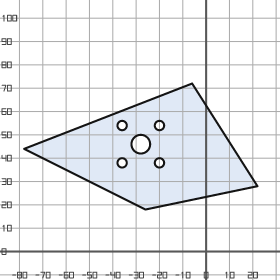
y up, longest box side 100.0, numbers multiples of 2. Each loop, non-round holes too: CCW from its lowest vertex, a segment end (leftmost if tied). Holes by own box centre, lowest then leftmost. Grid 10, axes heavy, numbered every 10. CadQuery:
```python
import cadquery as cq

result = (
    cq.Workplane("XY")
    .moveTo(-26.0, 18.0)
    .lineTo(22.0, 28.0)
    .lineTo(-6.0, 72.0)
    .lineTo(-78.0, 44.0)
    .close()
    .moveTo(-36.0, 38.0)
    .circle(2.0)
    .moveTo(-20.0, 38.0)
    .circle(2.0)
    .moveTo(-28.0, 46.0)
    .circle(4.0)
    .moveTo(-36.0, 54.0)
    .circle(2.0)
    .moveTo(-20.0, 54.0)
    .circle(2.0)
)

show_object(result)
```